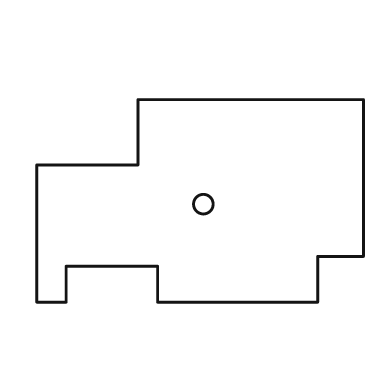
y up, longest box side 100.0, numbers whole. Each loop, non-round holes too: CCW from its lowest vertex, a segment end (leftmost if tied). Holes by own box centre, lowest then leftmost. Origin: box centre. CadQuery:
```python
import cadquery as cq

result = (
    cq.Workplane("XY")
    .moveTo(-50.0, -31.0)
    .lineTo(-41.0, -31.0)
    .lineTo(-41.0, -20.0)
    .lineTo(-13.0, -20.0)
    .lineTo(-13.0, -31.0)
    .lineTo(36.0, -31.0)
    .lineTo(36.0, -17.0)
    .lineTo(50.0, -17.0)
    .lineTo(50.0, 31.0)
    .lineTo(-19.0, 31.0)
    .lineTo(-19.0, 11.0)
    .lineTo(-50.0, 11.0)
    .close()
    .moveTo(1.0, -1.0)
    .circle(3.0)
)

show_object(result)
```